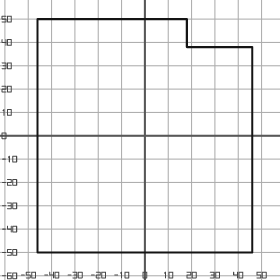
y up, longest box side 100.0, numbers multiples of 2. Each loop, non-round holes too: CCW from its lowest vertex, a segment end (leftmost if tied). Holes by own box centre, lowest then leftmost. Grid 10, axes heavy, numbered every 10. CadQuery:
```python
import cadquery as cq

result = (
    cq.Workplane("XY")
    .moveTo(-46.0, -50.0)
    .lineTo(46.0, -50.0)
    .lineTo(46.0, 38.0)
    .lineTo(18.0, 38.0)
    .lineTo(18.0, 50.0)
    .lineTo(-46.0, 50.0)
    .close()
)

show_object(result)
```